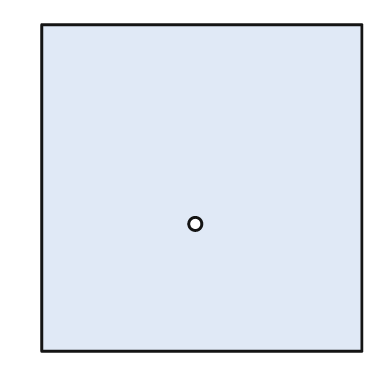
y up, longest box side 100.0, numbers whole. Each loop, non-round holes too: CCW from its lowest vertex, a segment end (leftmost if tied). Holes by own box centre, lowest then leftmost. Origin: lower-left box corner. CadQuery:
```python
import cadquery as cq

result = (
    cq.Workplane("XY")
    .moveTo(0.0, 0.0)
    .lineTo(98.0, 0.0)
    .lineTo(98.0, 100.0)
    .lineTo(0.0, 100.0)
    .close()
    .moveTo(47.0, 39.0)
    .circle(2.0)
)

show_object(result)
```